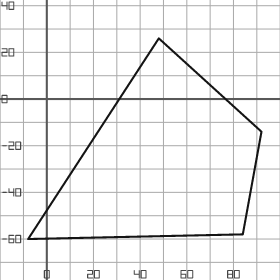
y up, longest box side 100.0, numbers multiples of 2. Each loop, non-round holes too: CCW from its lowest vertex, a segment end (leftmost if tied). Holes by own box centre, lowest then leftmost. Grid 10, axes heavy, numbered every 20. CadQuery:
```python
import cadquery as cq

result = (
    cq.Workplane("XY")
    .moveTo(-8.0, -60.0)
    .lineTo(84.0, -58.0)
    .lineTo(92.0, -14.0)
    .lineTo(48.0, 26.0)
    .close()
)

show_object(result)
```